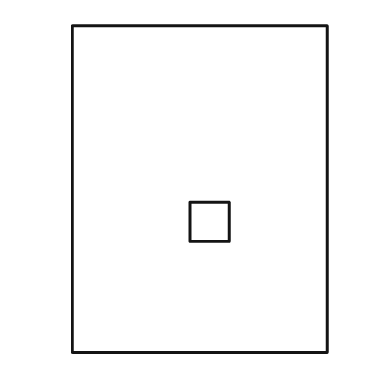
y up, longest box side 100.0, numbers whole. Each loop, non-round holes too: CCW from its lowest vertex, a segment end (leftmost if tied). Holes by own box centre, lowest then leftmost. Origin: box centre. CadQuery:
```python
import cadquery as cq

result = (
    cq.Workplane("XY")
    .moveTo(-39.0, -50.0)
    .lineTo(39.0, -50.0)
    .lineTo(39.0, 50.0)
    .lineTo(-39.0, 50.0)
    .close()
    .moveTo(-3.0, -16.0)
    .lineTo(9.0, -16.0)
    .lineTo(9.0, -4.0)
    .lineTo(-3.0, -4.0)
    .close()
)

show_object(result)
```